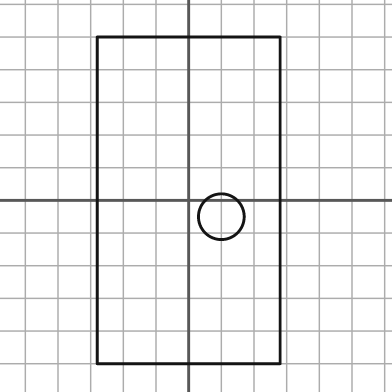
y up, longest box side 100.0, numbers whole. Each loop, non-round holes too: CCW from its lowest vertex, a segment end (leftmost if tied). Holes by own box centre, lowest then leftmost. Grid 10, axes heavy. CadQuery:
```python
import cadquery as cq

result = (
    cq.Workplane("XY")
    .moveTo(-28.0, -50.0)
    .lineTo(28.0, -50.0)
    .lineTo(28.0, 50.0)
    .lineTo(-28.0, 50.0)
    .close()
    .moveTo(10.0, -5.0)
    .circle(7.0)
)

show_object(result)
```